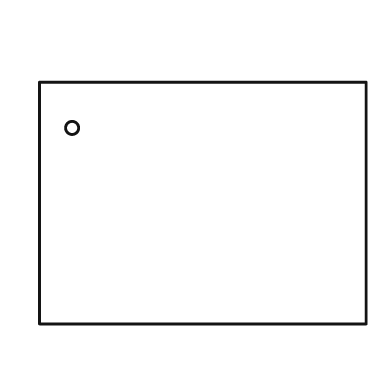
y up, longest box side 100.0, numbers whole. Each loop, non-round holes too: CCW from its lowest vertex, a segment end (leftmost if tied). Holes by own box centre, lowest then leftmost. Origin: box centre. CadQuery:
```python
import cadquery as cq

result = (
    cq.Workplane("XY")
    .moveTo(-50.0, -37.0)
    .lineTo(50.0, -37.0)
    .lineTo(50.0, 37.0)
    .lineTo(-50.0, 37.0)
    .close()
    .moveTo(-40.0, 23.0)
    .circle(2.0)
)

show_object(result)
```